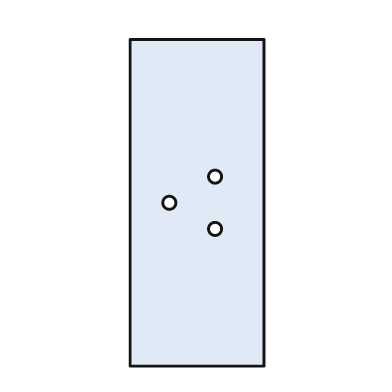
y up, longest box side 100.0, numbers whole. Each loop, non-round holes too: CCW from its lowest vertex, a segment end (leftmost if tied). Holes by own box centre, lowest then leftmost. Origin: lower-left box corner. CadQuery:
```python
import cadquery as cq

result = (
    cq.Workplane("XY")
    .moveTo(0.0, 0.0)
    .lineTo(41.0, 0.0)
    .lineTo(41.0, 100.0)
    .lineTo(0.0, 100.0)
    .close()
    .moveTo(26.0, 42.0)
    .circle(2.0)
    .moveTo(12.0, 50.0)
    .circle(2.0)
    .moveTo(26.0, 58.0)
    .circle(2.0)
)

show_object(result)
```